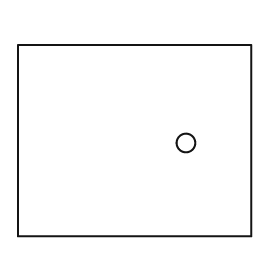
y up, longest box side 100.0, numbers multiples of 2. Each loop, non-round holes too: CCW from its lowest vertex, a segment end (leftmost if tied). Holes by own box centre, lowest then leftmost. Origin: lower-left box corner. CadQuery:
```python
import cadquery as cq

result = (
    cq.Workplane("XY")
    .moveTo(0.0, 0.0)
    .lineTo(100.0, 0.0)
    .lineTo(100.0, 82.0)
    .lineTo(0.0, 82.0)
    .close()
    .moveTo(72.0, 40.0)
    .circle(4.0)
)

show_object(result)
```